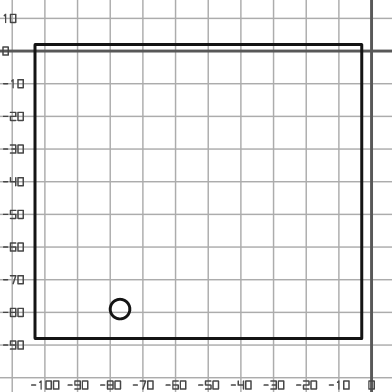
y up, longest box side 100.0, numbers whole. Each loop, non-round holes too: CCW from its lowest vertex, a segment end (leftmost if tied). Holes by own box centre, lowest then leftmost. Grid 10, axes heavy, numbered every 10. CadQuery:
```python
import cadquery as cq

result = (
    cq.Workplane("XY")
    .moveTo(-103.0, -88.0)
    .lineTo(-3.0, -88.0)
    .lineTo(-3.0, 2.0)
    .lineTo(-103.0, 2.0)
    .close()
    .moveTo(-77.0, -79.0)
    .circle(3.0)
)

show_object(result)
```